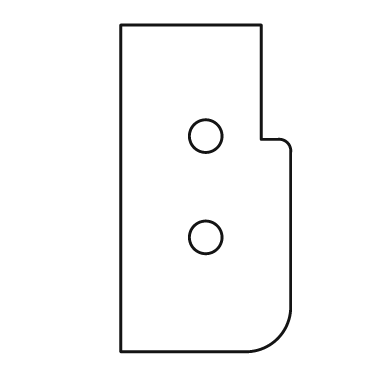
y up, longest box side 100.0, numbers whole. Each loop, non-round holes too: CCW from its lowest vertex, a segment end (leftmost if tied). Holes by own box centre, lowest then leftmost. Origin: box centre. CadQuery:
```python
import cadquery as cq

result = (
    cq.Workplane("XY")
    .moveTo(-26.0, -50.0)
    .lineTo(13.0, -50.0)
    .threePointArc((22.0, -46.0), (26.0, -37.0))
    .lineTo(26.0, 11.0)
    .threePointArc((25.0, 14.0), (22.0, 15.0))
    .lineTo(17.0, 15.0)
    .lineTo(17.0, 50.0)
    .lineTo(-26.0, 50.0)
    .close()
    .moveTo(0.0, -15.0)
    .circle(5.0)
    .moveTo(0.0, 16.0)
    .circle(5.0)
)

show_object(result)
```